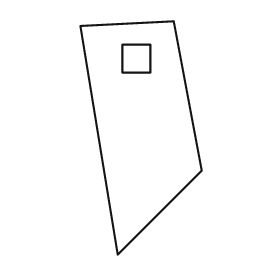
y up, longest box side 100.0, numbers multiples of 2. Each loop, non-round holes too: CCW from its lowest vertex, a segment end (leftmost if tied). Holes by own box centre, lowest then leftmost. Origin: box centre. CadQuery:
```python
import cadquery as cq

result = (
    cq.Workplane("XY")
    .moveTo(-10.0, -50.0)
    .lineTo(26.0, -14.0)
    .lineTo(14.0, 50.0)
    .lineTo(-26.0, 48.0)
    .close()
    .moveTo(-8.0, 28.0)
    .lineTo(4.0, 28.0)
    .lineTo(4.0, 40.0)
    .lineTo(-8.0, 40.0)
    .close()
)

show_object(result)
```